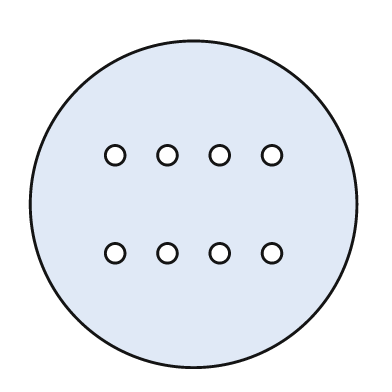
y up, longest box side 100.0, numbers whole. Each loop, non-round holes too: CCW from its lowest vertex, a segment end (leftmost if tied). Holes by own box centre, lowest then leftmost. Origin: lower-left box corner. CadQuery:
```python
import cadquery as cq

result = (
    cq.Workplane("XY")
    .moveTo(50.0, 50.0)
    .circle(50.0)
    .moveTo(26.0, 35.0)
    .circle(3.0)
    .moveTo(42.0, 35.0)
    .circle(3.0)
    .moveTo(58.0, 35.0)
    .circle(3.0)
    .moveTo(74.0, 35.0)
    .circle(3.0)
    .moveTo(26.0, 65.0)
    .circle(3.0)
    .moveTo(42.0, 65.0)
    .circle(3.0)
    .moveTo(58.0, 65.0)
    .circle(3.0)
    .moveTo(74.0, 65.0)
    .circle(3.0)
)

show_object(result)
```